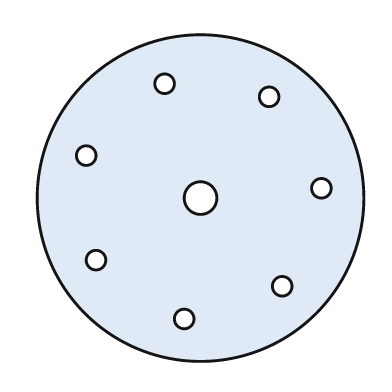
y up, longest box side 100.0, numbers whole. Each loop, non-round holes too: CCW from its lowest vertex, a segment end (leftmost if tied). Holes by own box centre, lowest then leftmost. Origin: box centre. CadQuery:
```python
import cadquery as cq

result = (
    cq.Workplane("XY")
    .moveTo(0.0, 0.0)
    .circle(50.0)
    .moveTo(-5.0, -37.0)
    .circle(3.0)
    .moveTo(25.0, -27.0)
    .circle(3.0)
    .moveTo(-32.0, -19.0)
    .circle(3.0)
    .moveTo(0.0, 0.0)
    .circle(5.0)
    .moveTo(37.0, 3.0)
    .circle(3.0)
    .moveTo(-35.0, 13.0)
    .circle(3.0)
    .moveTo(21.0, 31.0)
    .circle(3.0)
    .moveTo(-11.0, 35.0)
    .circle(3.0)
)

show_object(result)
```